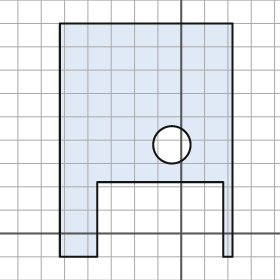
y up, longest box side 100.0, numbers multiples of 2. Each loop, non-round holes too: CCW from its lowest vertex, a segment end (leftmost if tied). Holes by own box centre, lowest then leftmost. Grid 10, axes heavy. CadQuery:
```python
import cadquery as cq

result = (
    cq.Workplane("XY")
    .moveTo(-52.0, -10.0)
    .lineTo(-36.0, -10.0)
    .lineTo(-36.0, 22.0)
    .lineTo(18.0, 22.0)
    .lineTo(18.0, -10.0)
    .lineTo(22.0, -10.0)
    .lineTo(22.0, 90.0)
    .lineTo(-52.0, 90.0)
    .close()
    .moveTo(-4.0, 38.0)
    .circle(8.0)
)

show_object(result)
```